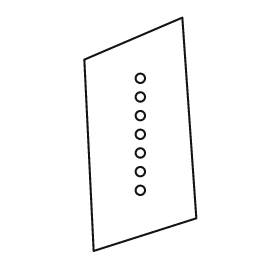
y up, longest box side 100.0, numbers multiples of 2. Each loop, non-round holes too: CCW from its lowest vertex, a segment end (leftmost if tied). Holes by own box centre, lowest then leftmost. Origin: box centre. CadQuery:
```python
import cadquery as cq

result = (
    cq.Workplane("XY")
    .moveTo(-20.0, -50.0)
    .lineTo(24.0, -36.0)
    .lineTo(18.0, 50.0)
    .lineTo(-24.0, 32.0)
    .close()
    .moveTo(0.0, -24.0)
    .circle(2.0)
    .moveTo(0.0, -16.0)
    .circle(2.0)
    .moveTo(0.0, -8.0)
    .circle(2.0)
    .moveTo(0.0, 0.0)
    .circle(2.0)
    .moveTo(0.0, 8.0)
    .circle(2.0)
    .moveTo(0.0, 16.0)
    .circle(2.0)
    .moveTo(0.0, 24.0)
    .circle(2.0)
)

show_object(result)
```